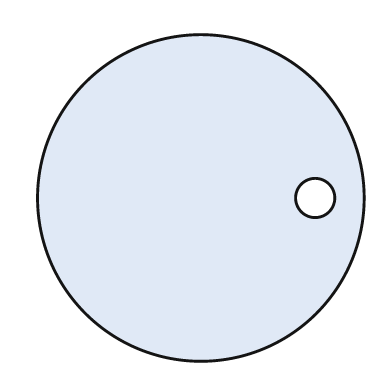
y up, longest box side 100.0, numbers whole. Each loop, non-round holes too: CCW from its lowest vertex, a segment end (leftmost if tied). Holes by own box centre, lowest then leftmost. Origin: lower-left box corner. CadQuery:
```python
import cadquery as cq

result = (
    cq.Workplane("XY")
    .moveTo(50.0, 50.0)
    .circle(50.0)
    .moveTo(85.0, 50.0)
    .circle(6.0)
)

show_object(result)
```